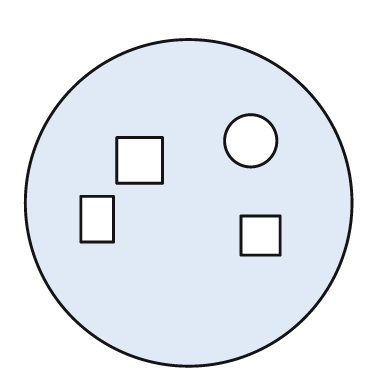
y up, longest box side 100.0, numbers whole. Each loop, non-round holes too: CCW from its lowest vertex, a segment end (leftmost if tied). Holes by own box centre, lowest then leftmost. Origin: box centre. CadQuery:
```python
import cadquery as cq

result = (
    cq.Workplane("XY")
    .moveTo(0.0, 0.0)
    .circle(50.0)
    .moveTo(16.0, -16.0)
    .lineTo(28.0, -16.0)
    .lineTo(28.0, -4.0)
    .lineTo(16.0, -4.0)
    .close()
    .moveTo(-33.0, -12.0)
    .lineTo(-23.0, -12.0)
    .lineTo(-23.0, 2.0)
    .lineTo(-33.0, 2.0)
    .close()
    .moveTo(-22.0, 6.0)
    .lineTo(-8.0, 6.0)
    .lineTo(-8.0, 20.0)
    .lineTo(-22.0, 20.0)
    .close()
    .moveTo(19.0, 19.0)
    .circle(8.0)
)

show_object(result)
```